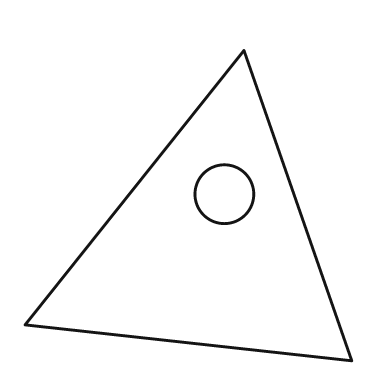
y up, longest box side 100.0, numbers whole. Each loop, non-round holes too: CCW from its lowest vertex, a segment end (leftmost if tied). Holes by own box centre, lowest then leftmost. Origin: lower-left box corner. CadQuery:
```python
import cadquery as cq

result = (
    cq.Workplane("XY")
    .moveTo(100.0, 0.0)
    .lineTo(67.0, 95.0)
    .lineTo(0.0, 11.0)
    .close()
    .moveTo(61.0, 51.0)
    .circle(9.0)
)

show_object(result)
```